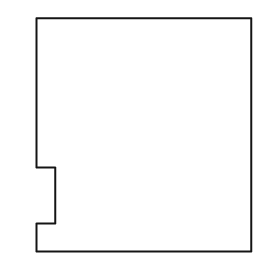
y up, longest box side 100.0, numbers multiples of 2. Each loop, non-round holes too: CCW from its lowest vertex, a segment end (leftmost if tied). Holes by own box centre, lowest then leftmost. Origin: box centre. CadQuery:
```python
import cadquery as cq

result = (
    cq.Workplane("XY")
    .moveTo(-46.0, -50.0)
    .lineTo(46.0, -50.0)
    .lineTo(46.0, 50.0)
    .lineTo(-46.0, 50.0)
    .lineTo(-46.0, -14.0)
    .lineTo(-38.0, -14.0)
    .lineTo(-38.0, -38.0)
    .lineTo(-46.0, -38.0)
    .close()
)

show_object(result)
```